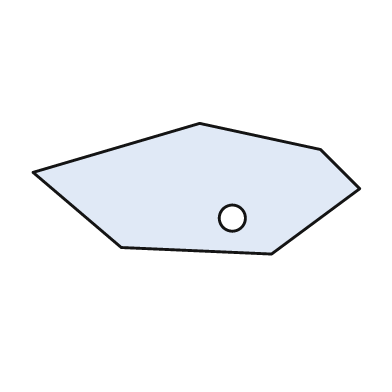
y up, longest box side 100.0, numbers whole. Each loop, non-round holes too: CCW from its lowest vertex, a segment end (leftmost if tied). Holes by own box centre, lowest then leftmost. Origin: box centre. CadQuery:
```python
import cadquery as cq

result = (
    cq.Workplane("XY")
    .moveTo(23.0, -20.0)
    .lineTo(50.0, 0.0)
    .lineTo(38.0, 12.0)
    .lineTo(1.0, 20.0)
    .lineTo(-50.0, 5.0)
    .lineTo(-23.0, -18.0)
    .close()
    .moveTo(11.0, -9.0)
    .circle(4.0)
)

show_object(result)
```